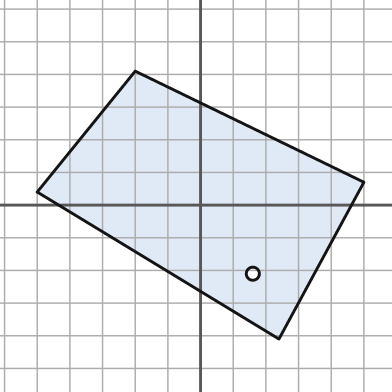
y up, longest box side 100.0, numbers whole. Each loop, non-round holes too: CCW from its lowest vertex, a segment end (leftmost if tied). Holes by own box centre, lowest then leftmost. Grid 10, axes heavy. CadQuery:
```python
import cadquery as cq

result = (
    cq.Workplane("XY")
    .moveTo(24.0, -41.0)
    .lineTo(50.0, 7.0)
    .lineTo(-20.0, 41.0)
    .lineTo(-50.0, 4.0)
    .close()
    .moveTo(16.0, -21.0)
    .circle(2.0)
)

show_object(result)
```